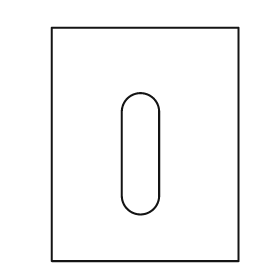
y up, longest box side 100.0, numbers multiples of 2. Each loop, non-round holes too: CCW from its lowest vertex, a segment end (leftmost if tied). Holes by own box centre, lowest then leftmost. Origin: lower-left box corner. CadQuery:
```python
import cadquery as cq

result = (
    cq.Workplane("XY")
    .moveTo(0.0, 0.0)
    .lineTo(80.0, 0.0)
    .lineTo(80.0, 100.0)
    .lineTo(0.0, 100.0)
    .close()
    .moveTo(30.0, 28.0)
    .threePointArc((38.0, 20.0), (46.0, 28.0))
    .lineTo(46.0, 64.0)
    .threePointArc((38.0, 72.0), (30.0, 64.0))
    .close()
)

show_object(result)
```